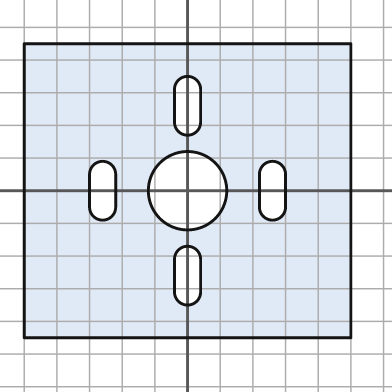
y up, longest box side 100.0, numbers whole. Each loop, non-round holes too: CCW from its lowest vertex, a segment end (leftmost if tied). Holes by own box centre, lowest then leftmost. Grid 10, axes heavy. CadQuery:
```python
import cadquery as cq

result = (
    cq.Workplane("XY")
    .moveTo(-50.0, -45.0)
    .lineTo(50.0, -45.0)
    .lineTo(50.0, 45.0)
    .lineTo(-50.0, 45.0)
    .close()
    .moveTo(-4.0, -31.0)
    .threePointArc((0.0, -35.0), (4.0, -31.0))
    .lineTo(4.0, -21.0)
    .threePointArc((0.0, -17.0), (-4.0, -21.0))
    .close()
    .moveTo(-30.0, -5.0)
    .threePointArc((-26.0, -9.0), (-22.0, -5.0))
    .lineTo(-22.0, 5.0)
    .threePointArc((-26.0, 9.0), (-30.0, 5.0))
    .close()
    .moveTo(0.0, 0.0)
    .circle(12.0)
    .moveTo(22.0, -5.0)
    .threePointArc((26.0, -9.0), (30.0, -5.0))
    .lineTo(30.0, 5.0)
    .threePointArc((26.0, 9.0), (22.0, 5.0))
    .close()
    .moveTo(-4.0, 21.0)
    .threePointArc((0.0, 17.0), (4.0, 21.0))
    .lineTo(4.0, 31.0)
    .threePointArc((0.0, 35.0), (-4.0, 31.0))
    .close()
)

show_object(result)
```